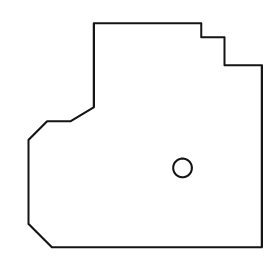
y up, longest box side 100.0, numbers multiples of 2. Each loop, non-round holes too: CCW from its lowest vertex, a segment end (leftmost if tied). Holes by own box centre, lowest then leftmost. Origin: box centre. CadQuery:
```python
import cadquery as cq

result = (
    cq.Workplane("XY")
    .moveTo(-40.0, -48.0)
    .lineTo(50.0, -48.0)
    .lineTo(50.0, 30.0)
    .lineTo(34.0, 30.0)
    .lineTo(34.0, 42.0)
    .lineTo(24.0, 42.0)
    .lineTo(24.0, 48.0)
    .lineTo(-22.0, 48.0)
    .lineTo(-22.0, 12.0)
    .lineTo(-32.0, 6.0)
    .lineTo(-42.0, 6.0)
    .lineTo(-50.0, -2.0)
    .lineTo(-50.0, -38.0)
    .close()
    .moveTo(16.0, -14.0)
    .circle(4.0)
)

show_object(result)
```